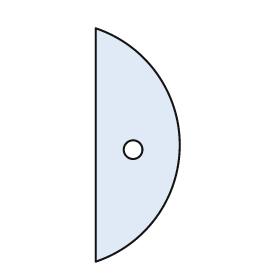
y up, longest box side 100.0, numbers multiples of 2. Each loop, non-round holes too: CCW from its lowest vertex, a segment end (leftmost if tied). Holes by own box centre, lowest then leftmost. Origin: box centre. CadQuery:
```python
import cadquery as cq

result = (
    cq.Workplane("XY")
    .moveTo(-18.0, -50.0)
    .threePointArc((18.0, 0.0), (-18.0, 50.0))
    .close()
    .moveTo(-2.0, -2.0)
    .circle(4.0)
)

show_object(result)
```